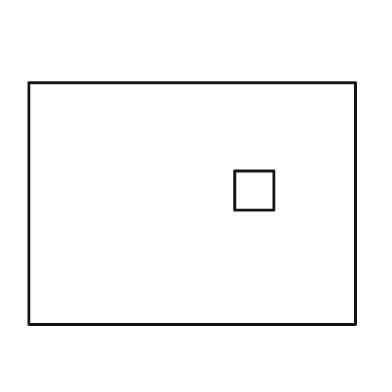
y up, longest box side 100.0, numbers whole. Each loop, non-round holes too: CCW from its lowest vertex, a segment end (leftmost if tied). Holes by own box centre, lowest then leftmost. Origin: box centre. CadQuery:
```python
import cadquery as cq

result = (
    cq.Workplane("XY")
    .moveTo(-50.0, -37.0)
    .lineTo(50.0, -37.0)
    .lineTo(50.0, 37.0)
    .lineTo(-50.0, 37.0)
    .close()
    .moveTo(13.0, -2.0)
    .lineTo(25.0, -2.0)
    .lineTo(25.0, 10.0)
    .lineTo(13.0, 10.0)
    .close()
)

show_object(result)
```